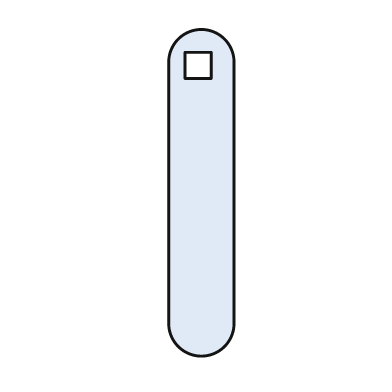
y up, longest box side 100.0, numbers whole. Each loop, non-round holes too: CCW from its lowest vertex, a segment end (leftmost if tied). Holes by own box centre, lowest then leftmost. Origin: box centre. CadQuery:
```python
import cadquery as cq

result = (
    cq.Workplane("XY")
    .moveTo(-10.0, -40.0)
    .threePointArc((0.0, -50.0), (10.0, -40.0))
    .lineTo(10.0, 40.0)
    .threePointArc((0.0, 50.0), (-10.0, 40.0))
    .close()
    .moveTo(-5.0, 35.0)
    .lineTo(3.0, 35.0)
    .lineTo(3.0, 43.0)
    .lineTo(-5.0, 43.0)
    .close()
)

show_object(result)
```